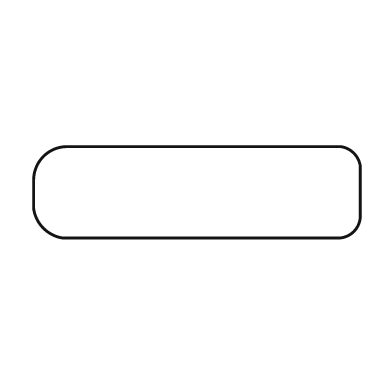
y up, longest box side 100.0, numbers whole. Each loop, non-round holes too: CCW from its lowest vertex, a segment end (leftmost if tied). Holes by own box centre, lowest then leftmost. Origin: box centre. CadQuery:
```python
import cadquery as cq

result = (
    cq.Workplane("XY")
    .moveTo(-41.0, -14.0)
    .lineTo(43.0, -14.0)
    .threePointArc((48.0, -12.0), (50.0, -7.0))
    .lineTo(50.0, 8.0)
    .threePointArc((48.0, 12.0), (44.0, 14.0))
    .lineTo(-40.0, 14.0)
    .threePointArc((-47.0, 11.0), (-50.0, 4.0))
    .lineTo(-50.0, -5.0)
    .threePointArc((-47.0, -11.0), (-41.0, -14.0))
    .close()
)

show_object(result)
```